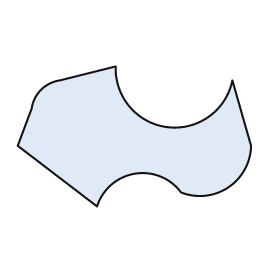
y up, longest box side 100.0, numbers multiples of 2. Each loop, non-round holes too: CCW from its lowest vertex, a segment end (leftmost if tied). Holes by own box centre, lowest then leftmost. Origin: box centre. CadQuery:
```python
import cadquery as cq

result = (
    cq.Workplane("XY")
    .moveTo(-16.0, -30.0)
    .threePointArc((0.0, -16.0), (20.0, -24.0))
    .threePointArc((40.0, -22.0), (50.0, -4.0))
    .lineTo(42.0, 24.0)
    .threePointArc((14.0, 4.0), (-8.0, 30.0))
    .lineTo(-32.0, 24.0)
    .threePointArc((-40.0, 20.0), (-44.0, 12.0))
    .lineTo(-50.0, -4.0)
    .close()
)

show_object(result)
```